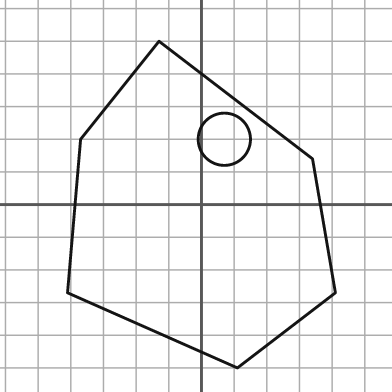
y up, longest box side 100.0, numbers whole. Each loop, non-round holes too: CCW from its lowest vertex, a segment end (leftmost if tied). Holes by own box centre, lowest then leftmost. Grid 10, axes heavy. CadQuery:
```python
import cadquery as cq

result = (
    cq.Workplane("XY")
    .moveTo(11.0, -50.0)
    .lineTo(41.0, -27.0)
    .lineTo(34.0, 14.0)
    .lineTo(-13.0, 50.0)
    .lineTo(-37.0, 20.0)
    .lineTo(-41.0, -27.0)
    .close()
    .moveTo(7.0, 20.0)
    .circle(8.0)
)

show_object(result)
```